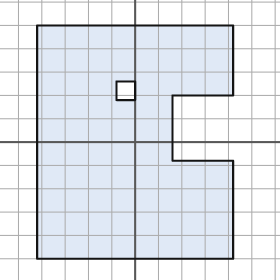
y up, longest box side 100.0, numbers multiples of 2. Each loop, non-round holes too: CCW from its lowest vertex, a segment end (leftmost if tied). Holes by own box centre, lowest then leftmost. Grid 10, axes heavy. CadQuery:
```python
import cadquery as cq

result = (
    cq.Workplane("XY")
    .moveTo(-42.0, -50.0)
    .lineTo(42.0, -50.0)
    .lineTo(42.0, -8.0)
    .lineTo(16.0, -8.0)
    .lineTo(16.0, 20.0)
    .lineTo(42.0, 20.0)
    .lineTo(42.0, 50.0)
    .lineTo(-42.0, 50.0)
    .close()
    .moveTo(-8.0, 18.0)
    .lineTo(0.0, 18.0)
    .lineTo(0.0, 26.0)
    .lineTo(-8.0, 26.0)
    .close()
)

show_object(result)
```